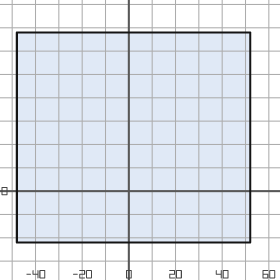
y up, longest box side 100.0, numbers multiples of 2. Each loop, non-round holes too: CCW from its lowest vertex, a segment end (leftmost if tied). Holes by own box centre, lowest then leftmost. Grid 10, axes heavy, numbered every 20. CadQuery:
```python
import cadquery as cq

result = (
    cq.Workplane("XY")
    .moveTo(-48.0, -22.0)
    .lineTo(52.0, -22.0)
    .lineTo(52.0, 68.0)
    .lineTo(-48.0, 68.0)
    .close()
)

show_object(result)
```